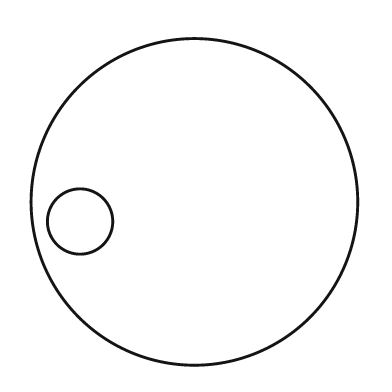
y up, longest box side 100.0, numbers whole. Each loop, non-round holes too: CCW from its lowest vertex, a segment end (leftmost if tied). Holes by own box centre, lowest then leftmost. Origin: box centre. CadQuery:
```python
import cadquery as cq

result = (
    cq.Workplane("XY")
    .moveTo(0.0, 0.0)
    .circle(50.0)
    .moveTo(-35.0, -6.0)
    .circle(10.0)
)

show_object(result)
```